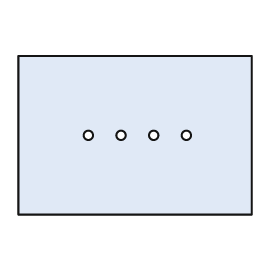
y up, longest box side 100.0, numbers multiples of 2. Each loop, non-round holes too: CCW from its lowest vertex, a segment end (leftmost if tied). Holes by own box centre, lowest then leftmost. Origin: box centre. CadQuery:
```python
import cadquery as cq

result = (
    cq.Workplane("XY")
    .moveTo(-50.0, -34.0)
    .lineTo(50.0, -34.0)
    .lineTo(50.0, 34.0)
    .lineTo(-50.0, 34.0)
    .close()
    .moveTo(-20.0, 0.0)
    .circle(2.0)
    .moveTo(-6.0, 0.0)
    .circle(2.0)
    .moveTo(8.0, 0.0)
    .circle(2.0)
    .moveTo(22.0, 0.0)
    .circle(2.0)
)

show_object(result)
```